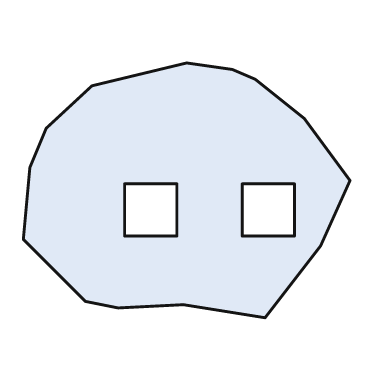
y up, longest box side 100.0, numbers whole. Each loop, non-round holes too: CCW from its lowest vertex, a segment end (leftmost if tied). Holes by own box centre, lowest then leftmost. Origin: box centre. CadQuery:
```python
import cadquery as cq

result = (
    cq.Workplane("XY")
    .moveTo(24.0, -39.0)
    .lineTo(41.0, -17.0)
    .lineTo(50.0, 3.0)
    .lineTo(36.0, 22.0)
    .lineTo(21.0, 34.0)
    .lineTo(14.0, 37.0)
    .lineTo(0.0, 39.0)
    .lineTo(-29.0, 32.0)
    .lineTo(-43.0, 19.0)
    .lineTo(-48.0, 7.0)
    .lineTo(-50.0, -15.0)
    .lineTo(-31.0, -34.0)
    .lineTo(-21.0, -36.0)
    .lineTo(-1.0, -35.0)
    .close()
    .moveTo(-19.0, -14.0)
    .lineTo(-3.0, -14.0)
    .lineTo(-3.0, 2.0)
    .lineTo(-19.0, 2.0)
    .close()
    .moveTo(17.0, -14.0)
    .lineTo(33.0, -14.0)
    .lineTo(33.0, 2.0)
    .lineTo(17.0, 2.0)
    .close()
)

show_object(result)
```